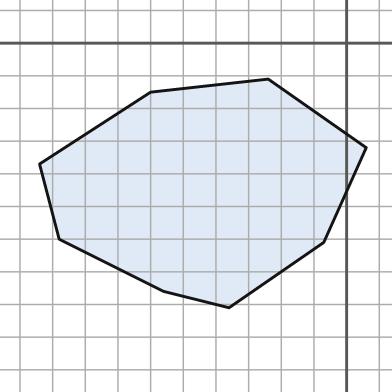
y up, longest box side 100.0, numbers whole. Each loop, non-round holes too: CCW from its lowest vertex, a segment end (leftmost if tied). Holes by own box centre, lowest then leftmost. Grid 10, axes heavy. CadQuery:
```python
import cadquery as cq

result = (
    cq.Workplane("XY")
    .moveTo(-36.0, -81.0)
    .lineTo(-7.0, -61.0)
    .lineTo(6.0, -32.0)
    .lineTo(-24.0, -11.0)
    .lineTo(-60.0, -15.0)
    .lineTo(-94.0, -37.0)
    .lineTo(-88.0, -60.0)
    .lineTo(-56.0, -76.0)
    .close()
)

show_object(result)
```